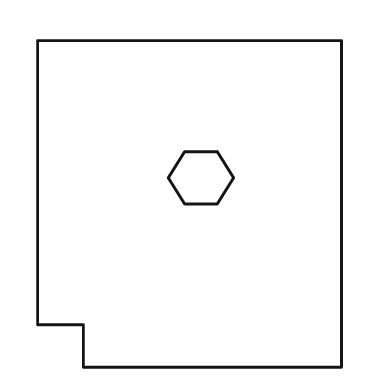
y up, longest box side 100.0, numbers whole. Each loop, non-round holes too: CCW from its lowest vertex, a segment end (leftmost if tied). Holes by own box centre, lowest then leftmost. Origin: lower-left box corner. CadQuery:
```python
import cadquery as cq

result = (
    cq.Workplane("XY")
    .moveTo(14.0, 0.0)
    .lineTo(93.0, 0.0)
    .lineTo(93.0, 100.0)
    .lineTo(0.0, 100.0)
    .lineTo(0.0, 13.0)
    .lineTo(14.0, 13.0)
    .close()
    .moveTo(45.0, 50.0)
    .lineTo(55.0, 50.0)
    .lineTo(60.0, 58.0)
    .lineTo(55.0, 66.0)
    .lineTo(45.0, 66.0)
    .lineTo(40.0, 58.0)
    .close()
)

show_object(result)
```